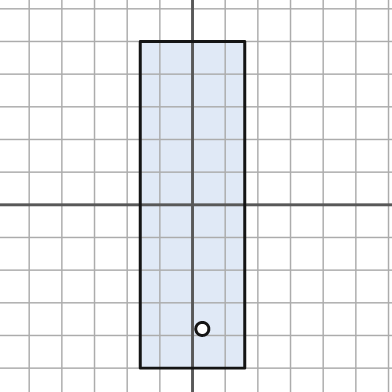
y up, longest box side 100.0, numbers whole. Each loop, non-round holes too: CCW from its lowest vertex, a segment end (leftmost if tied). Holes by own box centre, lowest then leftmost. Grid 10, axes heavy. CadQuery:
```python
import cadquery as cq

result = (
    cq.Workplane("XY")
    .moveTo(-16.0, -50.0)
    .lineTo(16.0, -50.0)
    .lineTo(16.0, 50.0)
    .lineTo(-16.0, 50.0)
    .close()
    .moveTo(3.0, -38.0)
    .circle(2.0)
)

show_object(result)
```